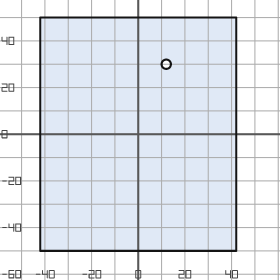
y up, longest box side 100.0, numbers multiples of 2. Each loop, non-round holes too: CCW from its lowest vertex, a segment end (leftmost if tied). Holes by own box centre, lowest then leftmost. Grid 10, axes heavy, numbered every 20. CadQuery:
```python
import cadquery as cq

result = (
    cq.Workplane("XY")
    .moveTo(-42.0, -50.0)
    .lineTo(42.0, -50.0)
    .lineTo(42.0, 50.0)
    .lineTo(-42.0, 50.0)
    .close()
    .moveTo(12.0, 30.0)
    .circle(2.0)
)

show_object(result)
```